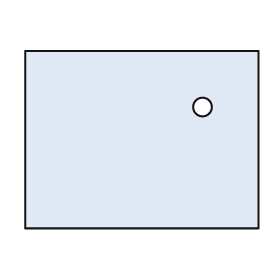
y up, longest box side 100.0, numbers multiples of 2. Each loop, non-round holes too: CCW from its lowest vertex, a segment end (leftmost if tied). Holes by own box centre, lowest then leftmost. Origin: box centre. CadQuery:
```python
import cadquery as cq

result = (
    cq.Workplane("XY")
    .moveTo(-50.0, -38.0)
    .lineTo(50.0, -38.0)
    .lineTo(50.0, 38.0)
    .lineTo(-50.0, 38.0)
    .close()
    .moveTo(26.0, 14.0)
    .circle(4.0)
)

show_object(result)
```